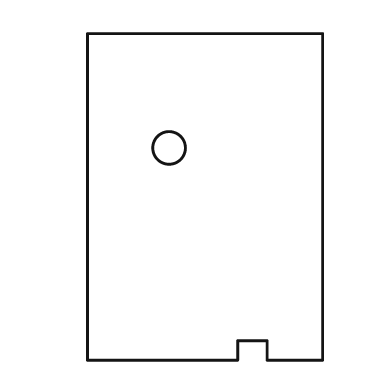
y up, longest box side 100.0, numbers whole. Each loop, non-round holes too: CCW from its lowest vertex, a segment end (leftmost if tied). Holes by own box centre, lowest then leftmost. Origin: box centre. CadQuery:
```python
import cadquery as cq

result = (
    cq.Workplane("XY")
    .moveTo(-36.0, -50.0)
    .lineTo(10.0, -50.0)
    .lineTo(10.0, -44.0)
    .lineTo(19.0, -44.0)
    .lineTo(19.0, -50.0)
    .lineTo(36.0, -50.0)
    .lineTo(36.0, 50.0)
    .lineTo(-36.0, 50.0)
    .close()
    .moveTo(-11.0, 15.0)
    .circle(5.0)
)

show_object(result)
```